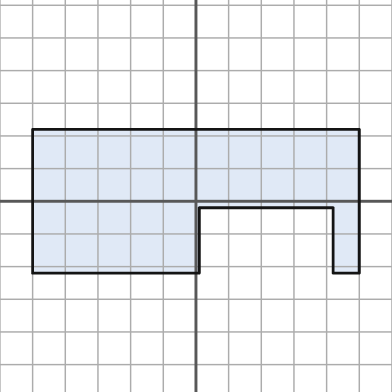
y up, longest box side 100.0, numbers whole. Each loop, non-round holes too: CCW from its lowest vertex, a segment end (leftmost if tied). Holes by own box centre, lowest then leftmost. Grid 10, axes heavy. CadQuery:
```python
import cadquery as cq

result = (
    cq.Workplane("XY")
    .moveTo(-50.0, -22.0)
    .lineTo(1.0, -22.0)
    .lineTo(1.0, -2.0)
    .lineTo(42.0, -2.0)
    .lineTo(42.0, -22.0)
    .lineTo(50.0, -22.0)
    .lineTo(50.0, 22.0)
    .lineTo(-50.0, 22.0)
    .close()
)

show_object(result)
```